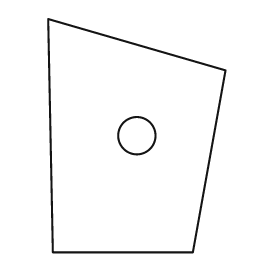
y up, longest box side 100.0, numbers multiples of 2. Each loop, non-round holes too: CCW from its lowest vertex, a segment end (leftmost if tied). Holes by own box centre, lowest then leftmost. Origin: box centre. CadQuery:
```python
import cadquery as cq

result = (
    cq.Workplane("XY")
    .moveTo(-36.0, -50.0)
    .lineTo(24.0, -50.0)
    .lineTo(38.0, 28.0)
    .lineTo(-38.0, 50.0)
    .close()
    .moveTo(0.0, 0.0)
    .circle(8.0)
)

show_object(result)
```